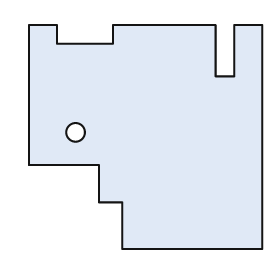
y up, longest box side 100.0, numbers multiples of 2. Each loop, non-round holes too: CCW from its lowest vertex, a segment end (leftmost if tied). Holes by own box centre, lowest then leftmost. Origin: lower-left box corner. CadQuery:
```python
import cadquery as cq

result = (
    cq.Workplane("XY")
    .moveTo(40.0, 0.0)
    .lineTo(100.0, 0.0)
    .lineTo(100.0, 96.0)
    .lineTo(88.0, 96.0)
    .lineTo(88.0, 74.0)
    .lineTo(80.0, 74.0)
    .lineTo(80.0, 96.0)
    .lineTo(36.0, 96.0)
    .lineTo(36.0, 88.0)
    .lineTo(12.0, 88.0)
    .lineTo(12.0, 96.0)
    .lineTo(0.0, 96.0)
    .lineTo(0.0, 36.0)
    .lineTo(30.0, 36.0)
    .lineTo(30.0, 20.0)
    .lineTo(40.0, 20.0)
    .close()
    .moveTo(20.0, 50.0)
    .circle(4.0)
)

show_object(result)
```